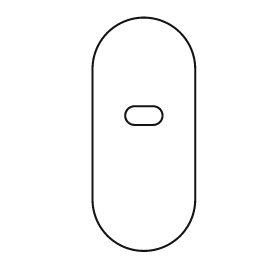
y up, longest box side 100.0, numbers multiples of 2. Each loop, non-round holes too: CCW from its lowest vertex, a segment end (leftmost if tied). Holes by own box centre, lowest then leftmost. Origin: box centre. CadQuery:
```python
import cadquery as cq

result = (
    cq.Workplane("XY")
    .moveTo(-22.0, -28.0)
    .threePointArc((0.0, -50.0), (22.0, -28.0))
    .lineTo(22.0, 28.0)
    .threePointArc((0.0, 50.0), (-22.0, 28.0))
    .close()
    .moveTo(-4.0, 4.0)
    .lineTo(4.0, 4.0)
    .threePointArc((8.0, 8.0), (4.0, 12.0))
    .lineTo(-4.0, 12.0)
    .threePointArc((-8.0, 8.0), (-4.0, 4.0))
    .close()
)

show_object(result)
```